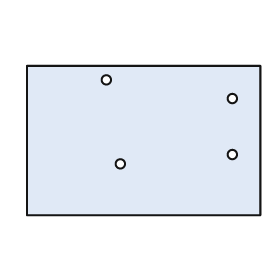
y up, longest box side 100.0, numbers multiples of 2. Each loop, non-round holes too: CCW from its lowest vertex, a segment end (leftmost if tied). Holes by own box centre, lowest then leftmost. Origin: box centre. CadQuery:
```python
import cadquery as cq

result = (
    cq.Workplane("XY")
    .moveTo(-50.0, -32.0)
    .lineTo(50.0, -32.0)
    .lineTo(50.0, 32.0)
    .lineTo(-50.0, 32.0)
    .close()
    .moveTo(-10.0, -10.0)
    .circle(2.0)
    .moveTo(38.0, -6.0)
    .circle(2.0)
    .moveTo(38.0, 18.0)
    .circle(2.0)
    .moveTo(-16.0, 26.0)
    .circle(2.0)
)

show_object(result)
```